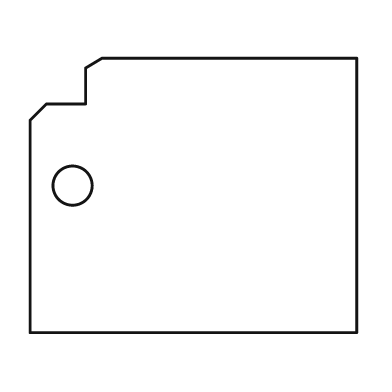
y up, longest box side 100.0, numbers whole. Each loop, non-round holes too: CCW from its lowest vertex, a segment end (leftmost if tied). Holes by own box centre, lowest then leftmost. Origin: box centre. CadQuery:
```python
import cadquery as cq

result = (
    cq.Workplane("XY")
    .moveTo(-50.0, -42.0)
    .lineTo(50.0, -42.0)
    .lineTo(50.0, 42.0)
    .lineTo(-28.0, 42.0)
    .lineTo(-33.0, 39.0)
    .lineTo(-33.0, 28.0)
    .lineTo(-45.0, 28.0)
    .lineTo(-50.0, 23.0)
    .close()
    .moveTo(-37.0, 3.0)
    .circle(6.0)
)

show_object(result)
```